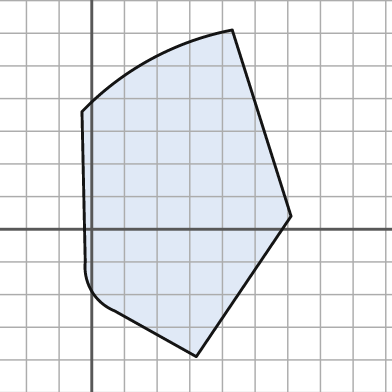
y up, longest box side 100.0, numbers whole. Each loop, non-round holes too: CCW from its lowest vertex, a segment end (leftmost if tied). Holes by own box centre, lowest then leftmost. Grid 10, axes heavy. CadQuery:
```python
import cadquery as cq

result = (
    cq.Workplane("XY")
    .moveTo(32.0, -39.0)
    .lineTo(61.0, 4.0)
    .lineTo(43.0, 61.0)
    .threePointArc((18.0, 52.0), (-3.0, 36.0))
    .lineTo(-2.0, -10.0)
    .threePointArc((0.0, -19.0), (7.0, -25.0))
    .close()
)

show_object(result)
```